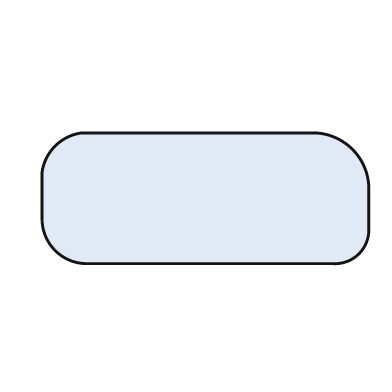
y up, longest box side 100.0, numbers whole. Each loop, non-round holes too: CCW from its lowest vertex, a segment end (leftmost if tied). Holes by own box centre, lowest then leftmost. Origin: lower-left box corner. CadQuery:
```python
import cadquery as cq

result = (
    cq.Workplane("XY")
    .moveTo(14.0, 0.0)
    .lineTo(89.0, 0.0)
    .threePointArc((97.0, 3.0), (100.0, 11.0))
    .lineTo(100.0, 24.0)
    .threePointArc((95.0, 35.0), (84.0, 40.0))
    .lineTo(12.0, 40.0)
    .threePointArc((4.0, 36.0), (0.0, 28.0))
    .lineTo(0.0, 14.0)
    .threePointArc((4.0, 4.0), (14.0, 0.0))
    .close()
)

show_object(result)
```